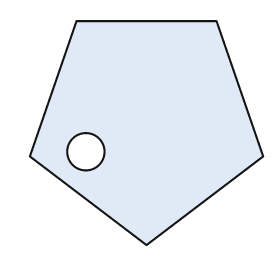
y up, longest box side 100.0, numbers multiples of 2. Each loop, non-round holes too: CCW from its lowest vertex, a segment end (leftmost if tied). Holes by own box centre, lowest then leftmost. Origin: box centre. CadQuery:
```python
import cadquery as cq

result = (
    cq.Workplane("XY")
    .moveTo(0.0, -48.0)
    .lineTo(50.0, -10.0)
    .lineTo(30.0, 48.0)
    .lineTo(-30.0, 48.0)
    .lineTo(-50.0, -10.0)
    .close()
    .moveTo(-26.0, -8.0)
    .circle(8.0)
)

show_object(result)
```